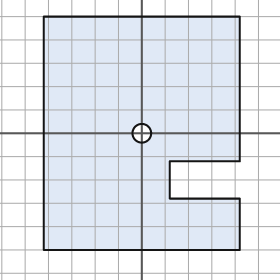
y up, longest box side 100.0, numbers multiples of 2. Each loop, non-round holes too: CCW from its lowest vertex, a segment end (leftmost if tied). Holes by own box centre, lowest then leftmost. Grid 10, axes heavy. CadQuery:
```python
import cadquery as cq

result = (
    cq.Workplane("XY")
    .moveTo(-42.0, -50.0)
    .lineTo(42.0, -50.0)
    .lineTo(42.0, -28.0)
    .lineTo(12.0, -28.0)
    .lineTo(12.0, -12.0)
    .lineTo(42.0, -12.0)
    .lineTo(42.0, 50.0)
    .lineTo(-42.0, 50.0)
    .close()
    .moveTo(0.0, 0.0)
    .circle(4.0)
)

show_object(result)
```